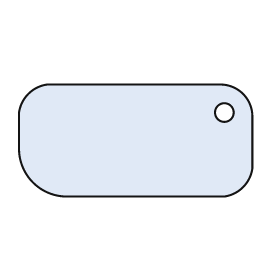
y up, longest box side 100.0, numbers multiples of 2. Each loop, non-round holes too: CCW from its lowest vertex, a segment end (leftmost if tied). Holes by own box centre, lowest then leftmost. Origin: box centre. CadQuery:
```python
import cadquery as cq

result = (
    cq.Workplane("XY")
    .moveTo(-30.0, -24.0)
    .lineTo(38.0, -24.0)
    .threePointArc((46.0, -20.0), (50.0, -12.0))
    .lineTo(50.0, 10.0)
    .threePointArc((46.0, 20.0), (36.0, 24.0))
    .lineTo(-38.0, 24.0)
    .threePointArc((-46.0, 20.0), (-50.0, 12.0))
    .lineTo(-50.0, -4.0)
    .threePointArc((-44.0, -18.0), (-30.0, -24.0))
    .close()
    .moveTo(38.0, 12.0)
    .circle(4.0)
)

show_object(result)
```